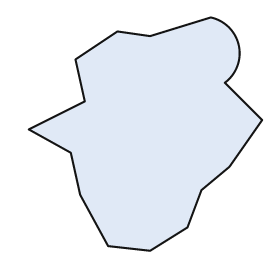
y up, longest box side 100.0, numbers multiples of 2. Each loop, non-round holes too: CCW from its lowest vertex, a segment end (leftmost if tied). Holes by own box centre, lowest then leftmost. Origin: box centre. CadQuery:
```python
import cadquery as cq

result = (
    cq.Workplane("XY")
    .moveTo(2.0, -50.0)
    .lineTo(18.0, -40.0)
    .lineTo(24.0, -24.0)
    .lineTo(36.0, -14.0)
    .lineTo(50.0, 6.0)
    .lineTo(34.0, 22.0)
    .threePointArc((40.0, 38.0), (28.0, 50.0))
    .lineTo(2.0, 42.0)
    .lineTo(-12.0, 44.0)
    .lineTo(-30.0, 32.0)
    .lineTo(-26.0, 14.0)
    .lineTo(-50.0, 2.0)
    .lineTo(-32.0, -8.0)
    .lineTo(-28.0, -26.0)
    .lineTo(-16.0, -48.0)
    .close()
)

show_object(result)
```